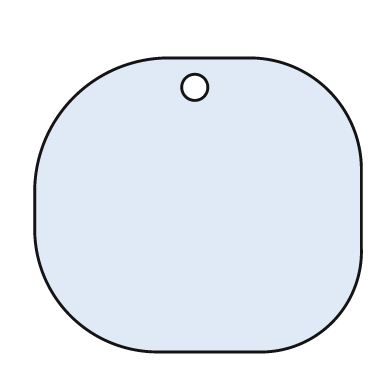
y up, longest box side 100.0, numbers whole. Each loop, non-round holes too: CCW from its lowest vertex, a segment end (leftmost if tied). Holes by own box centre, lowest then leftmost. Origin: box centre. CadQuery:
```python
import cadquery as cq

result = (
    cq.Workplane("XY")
    .moveTo(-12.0, -45.0)
    .lineTo(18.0, -45.0)
    .threePointArc((41.0, -36.0), (50.0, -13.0))
    .lineTo(50.0, 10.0)
    .threePointArc((40.0, 35.0), (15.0, 45.0))
    .lineTo(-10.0, 45.0)
    .threePointArc((-38.0, 33.0), (-50.0, 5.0))
    .lineTo(-50.0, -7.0)
    .threePointArc((-39.0, -34.0), (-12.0, -45.0))
    .close()
    .moveTo(-1.0, 36.0)
    .circle(4.0)
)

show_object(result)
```